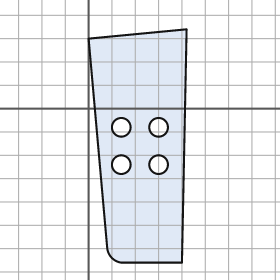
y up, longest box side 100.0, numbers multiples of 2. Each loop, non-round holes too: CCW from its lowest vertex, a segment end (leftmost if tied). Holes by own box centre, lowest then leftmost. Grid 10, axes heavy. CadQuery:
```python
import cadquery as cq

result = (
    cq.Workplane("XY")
    .moveTo(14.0, -66.0)
    .lineTo(40.0, -66.0)
    .lineTo(42.0, 34.0)
    .lineTo(0.0, 30.0)
    .lineTo(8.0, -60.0)
    .threePointArc((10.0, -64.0), (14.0, -66.0))
    .close()
    .moveTo(14.0, -24.0)
    .circle(4.0)
    .moveTo(30.0, -24.0)
    .circle(4.0)
    .moveTo(14.0, -8.0)
    .circle(4.0)
    .moveTo(30.0, -8.0)
    .circle(4.0)
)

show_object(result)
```